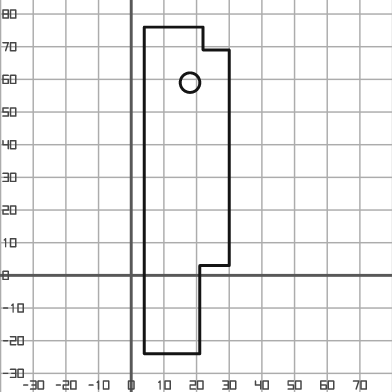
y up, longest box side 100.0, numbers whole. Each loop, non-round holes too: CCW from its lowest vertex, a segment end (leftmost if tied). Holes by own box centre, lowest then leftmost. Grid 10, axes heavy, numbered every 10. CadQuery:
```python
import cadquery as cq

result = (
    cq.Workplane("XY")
    .moveTo(4.0, -24.0)
    .lineTo(21.0, -24.0)
    .lineTo(21.0, 3.0)
    .lineTo(30.0, 3.0)
    .lineTo(30.0, 69.0)
    .lineTo(22.0, 69.0)
    .lineTo(22.0, 76.0)
    .lineTo(4.0, 76.0)
    .close()
    .moveTo(18.0, 59.0)
    .circle(3.0)
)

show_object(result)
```